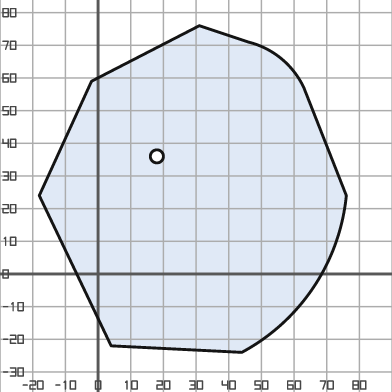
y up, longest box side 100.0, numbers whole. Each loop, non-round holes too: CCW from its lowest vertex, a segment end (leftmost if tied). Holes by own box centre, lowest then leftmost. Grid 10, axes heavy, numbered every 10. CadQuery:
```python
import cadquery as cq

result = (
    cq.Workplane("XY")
    .moveTo(44.0, -24.0)
    .threePointArc((66.0, -4.0), (76.0, 24.0))
    .lineTo(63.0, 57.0)
    .threePointArc((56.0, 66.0), (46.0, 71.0))
    .lineTo(31.0, 76.0)
    .lineTo(-2.0, 59.0)
    .lineTo(-18.0, 24.0)
    .lineTo(4.0, -22.0)
    .close()
    .moveTo(18.0, 36.0)
    .circle(2.0)
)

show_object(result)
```